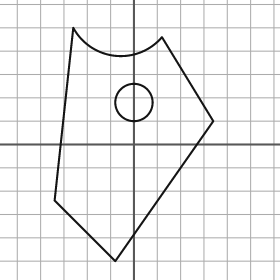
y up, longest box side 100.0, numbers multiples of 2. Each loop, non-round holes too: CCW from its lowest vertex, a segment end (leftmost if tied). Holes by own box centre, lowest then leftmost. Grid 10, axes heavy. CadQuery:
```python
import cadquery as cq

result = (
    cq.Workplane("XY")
    .moveTo(-8.0, -50.0)
    .lineTo(34.0, 10.0)
    .lineTo(12.0, 46.0)
    .threePointArc((-8.0, 38.0), (-26.0, 50.0))
    .lineTo(-34.0, -24.0)
    .close()
    .moveTo(0.0, 18.0)
    .circle(8.0)
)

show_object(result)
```